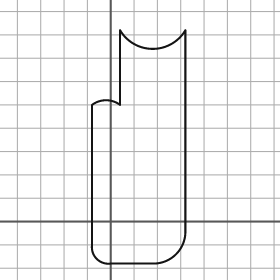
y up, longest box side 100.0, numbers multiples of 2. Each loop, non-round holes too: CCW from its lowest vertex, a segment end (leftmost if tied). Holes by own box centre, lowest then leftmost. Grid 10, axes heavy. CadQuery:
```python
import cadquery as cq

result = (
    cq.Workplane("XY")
    .moveTo(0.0, -18.0)
    .lineTo(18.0, -18.0)
    .threePointArc((28.0, -14.0), (32.0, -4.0))
    .lineTo(32.0, 82.0)
    .threePointArc((18.0, 74.0), (4.0, 82.0))
    .lineTo(4.0, 50.0)
    .threePointArc((-2.0, 52.0), (-8.0, 50.0))
    .lineTo(-8.0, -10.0)
    .threePointArc((-6.0, -16.0), (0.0, -18.0))
    .close()
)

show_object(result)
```